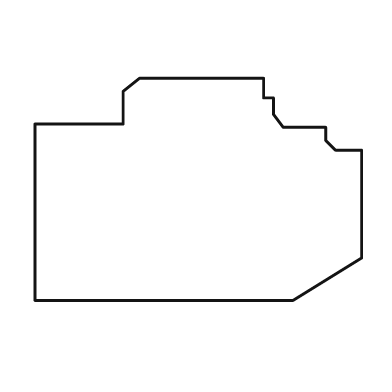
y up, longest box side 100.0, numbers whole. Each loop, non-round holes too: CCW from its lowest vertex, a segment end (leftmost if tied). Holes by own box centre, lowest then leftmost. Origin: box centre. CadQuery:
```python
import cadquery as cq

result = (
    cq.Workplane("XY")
    .moveTo(-50.0, -34.0)
    .lineTo(29.0, -34.0)
    .lineTo(50.0, -21.0)
    .lineTo(50.0, 12.0)
    .lineTo(42.0, 12.0)
    .lineTo(39.0, 15.0)
    .lineTo(39.0, 19.0)
    .lineTo(26.0, 19.0)
    .lineTo(23.0, 23.0)
    .lineTo(23.0, 28.0)
    .lineTo(20.0, 28.0)
    .lineTo(20.0, 34.0)
    .lineTo(-18.0, 34.0)
    .lineTo(-23.0, 30.0)
    .lineTo(-23.0, 20.0)
    .lineTo(-50.0, 20.0)
    .close()
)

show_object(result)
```